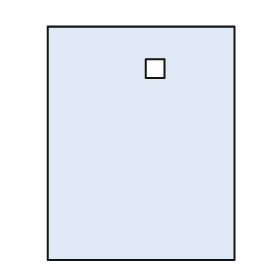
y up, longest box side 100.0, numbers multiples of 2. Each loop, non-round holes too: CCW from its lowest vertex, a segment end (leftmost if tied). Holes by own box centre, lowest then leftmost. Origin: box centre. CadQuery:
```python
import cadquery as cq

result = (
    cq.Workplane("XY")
    .moveTo(-40.0, -50.0)
    .lineTo(40.0, -50.0)
    .lineTo(40.0, 50.0)
    .lineTo(-40.0, 50.0)
    .close()
    .moveTo(2.0, 28.0)
    .lineTo(10.0, 28.0)
    .lineTo(10.0, 36.0)
    .lineTo(2.0, 36.0)
    .close()
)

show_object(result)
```